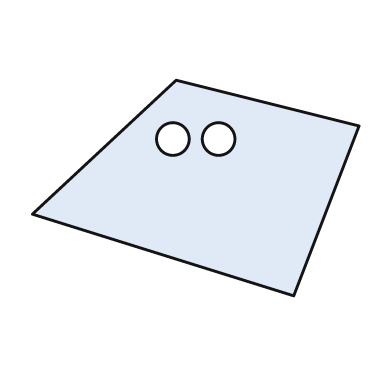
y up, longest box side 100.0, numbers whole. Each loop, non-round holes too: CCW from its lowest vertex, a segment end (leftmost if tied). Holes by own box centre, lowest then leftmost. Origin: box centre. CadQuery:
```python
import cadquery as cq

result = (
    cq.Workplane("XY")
    .moveTo(30.0, -33.0)
    .lineTo(50.0, 19.0)
    .lineTo(-6.0, 33.0)
    .lineTo(-50.0, -8.0)
    .close()
    .moveTo(-7.0, 15.0)
    .circle(5.0)
    .moveTo(7.0, 15.0)
    .circle(5.0)
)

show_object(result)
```